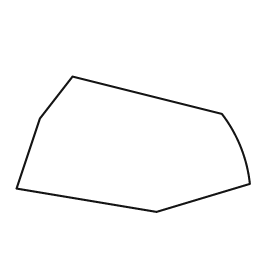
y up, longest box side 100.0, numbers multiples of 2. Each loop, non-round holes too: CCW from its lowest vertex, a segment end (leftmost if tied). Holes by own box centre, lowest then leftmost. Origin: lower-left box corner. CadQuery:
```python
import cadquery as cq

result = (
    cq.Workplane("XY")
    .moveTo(60.0, 0.0)
    .lineTo(100.0, 12.0)
    .threePointArc((96.0, 28.0), (88.0, 42.0))
    .lineTo(24.0, 58.0)
    .lineTo(10.0, 40.0)
    .lineTo(0.0, 10.0)
    .close()
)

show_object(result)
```